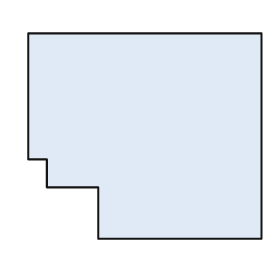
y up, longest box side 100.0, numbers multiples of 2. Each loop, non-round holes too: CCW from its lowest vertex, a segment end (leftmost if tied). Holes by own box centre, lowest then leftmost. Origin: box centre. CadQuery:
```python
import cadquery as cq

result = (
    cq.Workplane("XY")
    .moveTo(-20.0, -44.0)
    .lineTo(50.0, -44.0)
    .lineTo(50.0, 44.0)
    .lineTo(-50.0, 44.0)
    .lineTo(-50.0, -10.0)
    .lineTo(-42.0, -10.0)
    .lineTo(-42.0, -22.0)
    .lineTo(-20.0, -22.0)
    .close()
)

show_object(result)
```